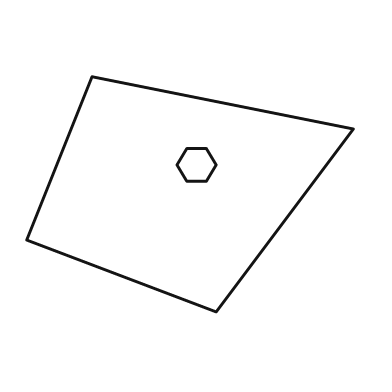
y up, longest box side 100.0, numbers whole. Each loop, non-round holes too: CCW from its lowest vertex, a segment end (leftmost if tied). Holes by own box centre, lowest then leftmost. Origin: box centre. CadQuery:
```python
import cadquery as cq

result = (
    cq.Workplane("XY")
    .moveTo(8.0, -36.0)
    .lineTo(50.0, 20.0)
    .lineTo(-30.0, 36.0)
    .lineTo(-50.0, -14.0)
    .close()
    .moveTo(-1.0, 4.0)
    .lineTo(5.0, 4.0)
    .lineTo(8.0, 9.0)
    .lineTo(5.0, 14.0)
    .lineTo(-1.0, 14.0)
    .lineTo(-4.0, 9.0)
    .close()
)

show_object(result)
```